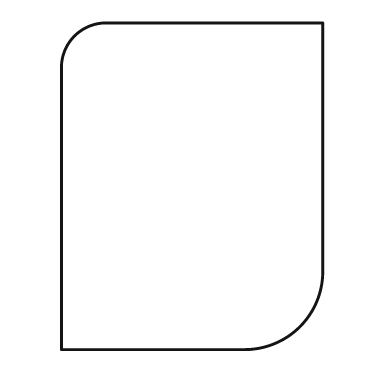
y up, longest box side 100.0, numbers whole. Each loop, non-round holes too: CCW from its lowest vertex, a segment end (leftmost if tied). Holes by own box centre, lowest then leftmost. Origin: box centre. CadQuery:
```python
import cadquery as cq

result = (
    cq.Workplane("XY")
    .moveTo(-40.0, -50.0)
    .lineTo(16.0, -50.0)
    .threePointArc((33.0, -43.0), (40.0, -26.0))
    .lineTo(40.0, 50.0)
    .lineTo(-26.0, 50.0)
    .threePointArc((-36.0, 46.0), (-40.0, 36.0))
    .close()
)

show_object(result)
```